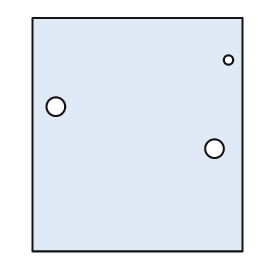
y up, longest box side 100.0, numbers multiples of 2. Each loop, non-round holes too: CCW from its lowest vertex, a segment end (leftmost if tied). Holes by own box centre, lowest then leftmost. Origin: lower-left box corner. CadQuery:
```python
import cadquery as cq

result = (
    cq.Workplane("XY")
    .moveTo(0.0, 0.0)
    .lineTo(90.0, 0.0)
    .lineTo(90.0, 100.0)
    .lineTo(0.0, 100.0)
    .close()
    .moveTo(78.0, 44.0)
    .circle(4.0)
    .moveTo(10.0, 62.0)
    .circle(4.0)
    .moveTo(84.0, 82.0)
    .circle(2.0)
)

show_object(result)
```